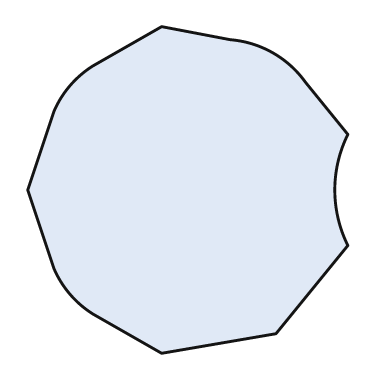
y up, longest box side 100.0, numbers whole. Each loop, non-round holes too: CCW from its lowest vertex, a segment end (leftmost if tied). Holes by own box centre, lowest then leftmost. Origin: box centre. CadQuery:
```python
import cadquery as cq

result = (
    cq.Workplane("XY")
    .moveTo(-8.0, -50.0)
    .lineTo(27.0, -44.0)
    .lineTo(49.0, -17.0)
    .threePointArc((45.0, 0.0), (49.0, 17.0))
    .lineTo(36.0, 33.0)
    .threePointArc((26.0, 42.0), (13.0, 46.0))
    .lineTo(-8.0, 50.0)
    .lineTo(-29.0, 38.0)
    .threePointArc((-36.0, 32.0), (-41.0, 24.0))
    .lineTo(-49.0, 0.0)
    .lineTo(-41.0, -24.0)
    .threePointArc((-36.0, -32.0), (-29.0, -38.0))
    .close()
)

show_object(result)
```